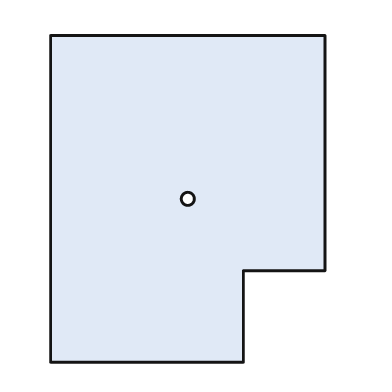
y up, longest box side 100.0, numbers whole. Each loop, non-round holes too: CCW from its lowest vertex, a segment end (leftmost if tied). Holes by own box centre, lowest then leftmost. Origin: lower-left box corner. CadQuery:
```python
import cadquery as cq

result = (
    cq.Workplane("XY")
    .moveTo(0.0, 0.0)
    .lineTo(59.0, 0.0)
    .lineTo(59.0, 28.0)
    .lineTo(84.0, 28.0)
    .lineTo(84.0, 100.0)
    .lineTo(0.0, 100.0)
    .close()
    .moveTo(42.0, 50.0)
    .circle(2.0)
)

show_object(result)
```